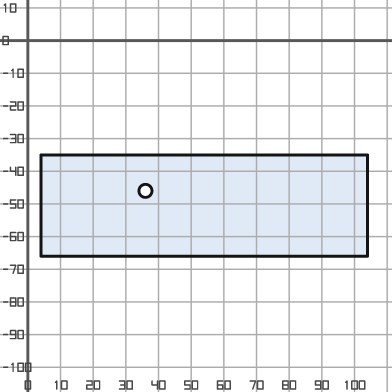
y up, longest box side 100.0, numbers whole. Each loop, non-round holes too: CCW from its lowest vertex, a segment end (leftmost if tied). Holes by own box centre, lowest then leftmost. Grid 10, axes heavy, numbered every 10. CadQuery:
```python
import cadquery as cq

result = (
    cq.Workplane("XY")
    .moveTo(4.0, -66.0)
    .lineTo(104.0, -66.0)
    .lineTo(104.0, -35.0)
    .lineTo(4.0, -35.0)
    .close()
    .moveTo(36.0, -46.0)
    .circle(2.0)
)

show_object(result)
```